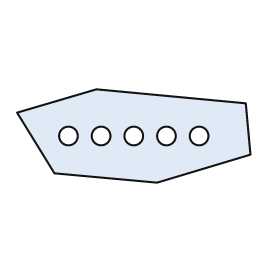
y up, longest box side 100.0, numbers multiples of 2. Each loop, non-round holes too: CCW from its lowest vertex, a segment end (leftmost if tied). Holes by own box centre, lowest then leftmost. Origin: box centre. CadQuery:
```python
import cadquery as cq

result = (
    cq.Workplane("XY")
    .moveTo(10.0, -20.0)
    .lineTo(50.0, -8.0)
    .lineTo(48.0, 14.0)
    .lineTo(-16.0, 20.0)
    .lineTo(-50.0, 10.0)
    .lineTo(-34.0, -16.0)
    .close()
    .moveTo(-28.0, 0.0)
    .circle(4.0)
    .moveTo(-14.0, 0.0)
    .circle(4.0)
    .moveTo(0.0, 0.0)
    .circle(4.0)
    .moveTo(14.0, 0.0)
    .circle(4.0)
    .moveTo(28.0, 0.0)
    .circle(4.0)
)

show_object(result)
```